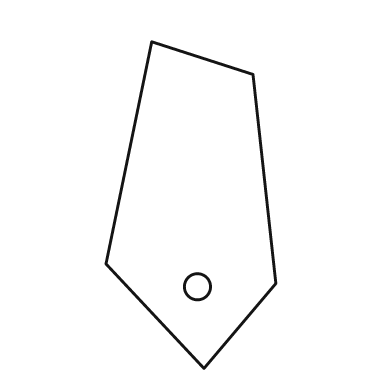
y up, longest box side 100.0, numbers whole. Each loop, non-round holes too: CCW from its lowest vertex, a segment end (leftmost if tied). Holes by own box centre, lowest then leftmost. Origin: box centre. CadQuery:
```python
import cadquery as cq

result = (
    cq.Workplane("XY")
    .moveTo(4.0, -50.0)
    .lineTo(26.0, -24.0)
    .lineTo(19.0, 40.0)
    .lineTo(-12.0, 50.0)
    .lineTo(-26.0, -18.0)
    .close()
    .moveTo(2.0, -25.0)
    .circle(4.0)
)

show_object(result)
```